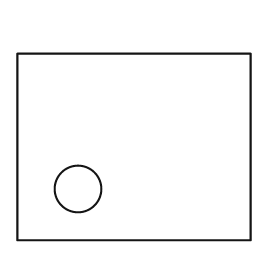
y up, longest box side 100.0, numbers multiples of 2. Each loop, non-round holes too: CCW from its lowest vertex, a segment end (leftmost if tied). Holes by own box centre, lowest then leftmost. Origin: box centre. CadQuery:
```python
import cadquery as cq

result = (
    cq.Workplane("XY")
    .moveTo(-50.0, -40.0)
    .lineTo(50.0, -40.0)
    .lineTo(50.0, 40.0)
    .lineTo(-50.0, 40.0)
    .close()
    .moveTo(-24.0, -18.0)
    .circle(10.0)
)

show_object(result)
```